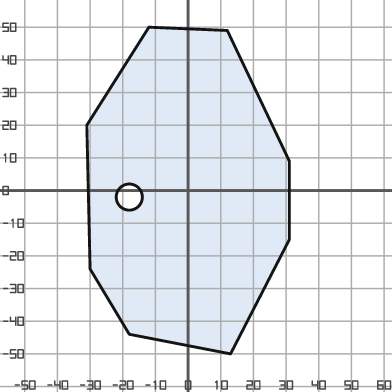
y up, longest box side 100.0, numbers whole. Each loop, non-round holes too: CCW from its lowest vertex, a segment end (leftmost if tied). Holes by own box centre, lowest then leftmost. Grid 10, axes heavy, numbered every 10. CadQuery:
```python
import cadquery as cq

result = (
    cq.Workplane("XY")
    .moveTo(13.0, -50.0)
    .lineTo(31.0, -15.0)
    .lineTo(31.0, 9.0)
    .lineTo(12.0, 49.0)
    .lineTo(-12.0, 50.0)
    .lineTo(-31.0, 20.0)
    .lineTo(-30.0, -24.0)
    .lineTo(-18.0, -44.0)
    .close()
    .moveTo(-18.0, -2.0)
    .circle(4.0)
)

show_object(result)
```